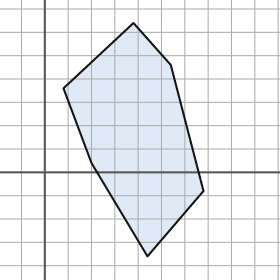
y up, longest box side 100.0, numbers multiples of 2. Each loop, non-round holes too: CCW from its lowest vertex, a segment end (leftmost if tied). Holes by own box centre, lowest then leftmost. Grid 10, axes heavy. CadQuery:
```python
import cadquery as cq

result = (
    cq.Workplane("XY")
    .moveTo(44.0, -36.0)
    .lineTo(68.0, -8.0)
    .lineTo(54.0, 46.0)
    .lineTo(38.0, 64.0)
    .lineTo(8.0, 36.0)
    .lineTo(20.0, 4.0)
    .close()
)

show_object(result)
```